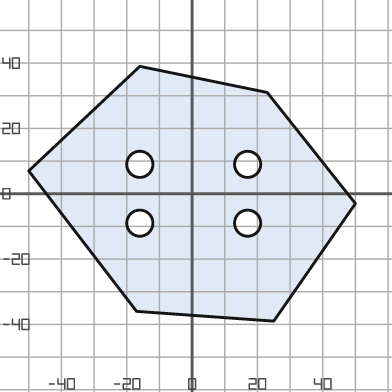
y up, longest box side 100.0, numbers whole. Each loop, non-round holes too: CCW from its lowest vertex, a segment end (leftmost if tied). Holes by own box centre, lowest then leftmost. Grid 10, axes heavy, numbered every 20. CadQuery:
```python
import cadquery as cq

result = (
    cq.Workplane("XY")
    .moveTo(25.0, -39.0)
    .lineTo(50.0, -3.0)
    .lineTo(23.0, 31.0)
    .lineTo(-16.0, 39.0)
    .lineTo(-50.0, 7.0)
    .lineTo(-17.0, -36.0)
    .close()
    .moveTo(-16.0, -9.0)
    .circle(4.0)
    .moveTo(17.0, -9.0)
    .circle(4.0)
    .moveTo(-16.0, 9.0)
    .circle(4.0)
    .moveTo(17.0, 9.0)
    .circle(4.0)
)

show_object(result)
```